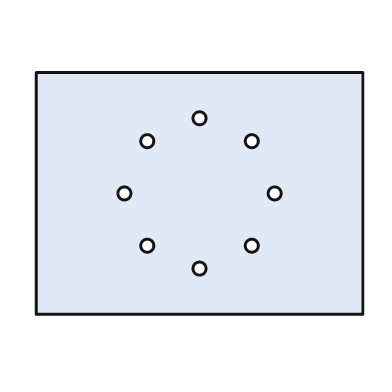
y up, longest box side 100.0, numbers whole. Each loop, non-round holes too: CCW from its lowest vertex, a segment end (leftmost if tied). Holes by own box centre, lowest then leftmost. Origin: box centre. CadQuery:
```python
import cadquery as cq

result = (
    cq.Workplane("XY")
    .moveTo(-50.0, -37.0)
    .lineTo(50.0, -37.0)
    .lineTo(50.0, 37.0)
    .lineTo(-50.0, 37.0)
    .close()
    .moveTo(0.0, -23.0)
    .circle(2.0)
    .moveTo(-16.0, -16.0)
    .circle(2.0)
    .moveTo(16.0, -16.0)
    .circle(2.0)
    .moveTo(-23.0, 0.0)
    .circle(2.0)
    .moveTo(23.0, 0.0)
    .circle(2.0)
    .moveTo(-16.0, 16.0)
    .circle(2.0)
    .moveTo(16.0, 16.0)
    .circle(2.0)
    .moveTo(0.0, 23.0)
    .circle(2.0)
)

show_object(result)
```